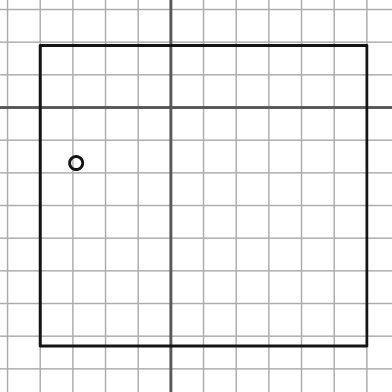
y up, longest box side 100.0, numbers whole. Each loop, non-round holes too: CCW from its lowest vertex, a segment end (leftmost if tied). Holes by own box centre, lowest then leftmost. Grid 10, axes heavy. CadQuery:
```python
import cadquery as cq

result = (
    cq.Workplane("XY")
    .moveTo(-40.0, -73.0)
    .lineTo(60.0, -73.0)
    .lineTo(60.0, 19.0)
    .lineTo(-40.0, 19.0)
    .close()
    .moveTo(-29.0, -17.0)
    .circle(2.0)
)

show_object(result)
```